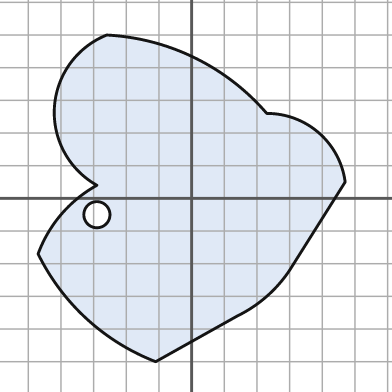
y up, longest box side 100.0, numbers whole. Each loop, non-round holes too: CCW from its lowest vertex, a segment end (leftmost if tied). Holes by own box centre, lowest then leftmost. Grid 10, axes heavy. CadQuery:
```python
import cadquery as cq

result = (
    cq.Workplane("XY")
    .moveTo(-11.0, -50.0)
    .lineTo(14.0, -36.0)
    .threePointArc((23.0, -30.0), (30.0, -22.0))
    .lineTo(47.0, 5.0)
    .threePointArc((39.0, 20.0), (23.0, 26.0))
    .threePointArc((1.0, 43.0), (-26.0, 50.0))
    .threePointArc((-42.0, 28.0), (-29.0, 4.0))
    .threePointArc((-40.0, -5.0), (-47.0, -17.0))
    .threePointArc((-32.0, -37.0), (-11.0, -50.0))
    .close()
    .moveTo(-29.0, -5.0)
    .circle(4.0)
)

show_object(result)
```